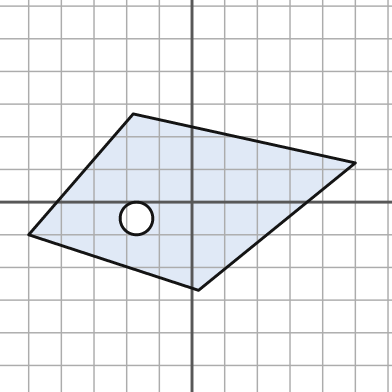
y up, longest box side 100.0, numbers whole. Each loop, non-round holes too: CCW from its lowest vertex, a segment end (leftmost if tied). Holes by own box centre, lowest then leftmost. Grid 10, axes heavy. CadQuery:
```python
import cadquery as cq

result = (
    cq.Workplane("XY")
    .moveTo(2.0, -27.0)
    .lineTo(50.0, 12.0)
    .lineTo(-18.0, 27.0)
    .lineTo(-50.0, -10.0)
    .close()
    .moveTo(-17.0, -5.0)
    .circle(5.0)
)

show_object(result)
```